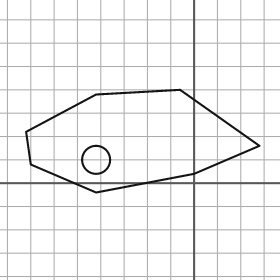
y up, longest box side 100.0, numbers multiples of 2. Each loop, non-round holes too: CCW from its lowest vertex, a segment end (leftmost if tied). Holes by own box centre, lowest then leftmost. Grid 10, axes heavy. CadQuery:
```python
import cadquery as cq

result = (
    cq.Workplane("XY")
    .moveTo(-42.0, -4.0)
    .lineTo(0.0, 4.0)
    .lineTo(28.0, 16.0)
    .lineTo(-6.0, 40.0)
    .lineTo(-42.0, 38.0)
    .lineTo(-72.0, 22.0)
    .lineTo(-70.0, 8.0)
    .close()
    .moveTo(-42.0, 10.0)
    .circle(6.0)
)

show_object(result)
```